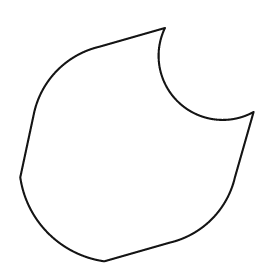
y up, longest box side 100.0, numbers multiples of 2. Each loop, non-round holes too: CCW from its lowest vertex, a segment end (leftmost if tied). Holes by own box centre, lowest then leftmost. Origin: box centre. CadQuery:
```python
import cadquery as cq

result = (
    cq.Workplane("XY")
    .moveTo(-14.0, -50.0)
    .lineTo(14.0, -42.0)
    .threePointArc((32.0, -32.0), (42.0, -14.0))
    .lineTo(50.0, 14.0)
    .threePointArc((18.0, 18.0), (12.0, 50.0))
    .lineTo(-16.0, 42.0)
    .threePointArc((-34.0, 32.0), (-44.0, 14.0))
    .lineTo(-50.0, -14.0)
    .threePointArc((-38.0, -38.0), (-14.0, -50.0))
    .close()
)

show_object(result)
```